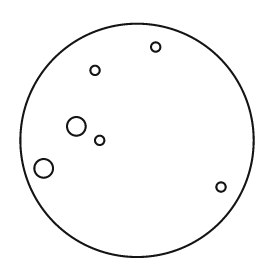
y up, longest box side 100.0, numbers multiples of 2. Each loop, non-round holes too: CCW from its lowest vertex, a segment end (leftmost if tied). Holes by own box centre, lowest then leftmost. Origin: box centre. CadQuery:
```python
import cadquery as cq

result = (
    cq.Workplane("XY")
    .moveTo(0.0, 0.0)
    .circle(50.0)
    .moveTo(36.0, -20.0)
    .circle(2.0)
    .moveTo(-40.0, -12.0)
    .circle(4.0)
    .moveTo(-16.0, 0.0)
    .circle(2.0)
    .moveTo(-26.0, 6.0)
    .circle(4.0)
    .moveTo(-18.0, 30.0)
    .circle(2.0)
    .moveTo(8.0, 40.0)
    .circle(2.0)
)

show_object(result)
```